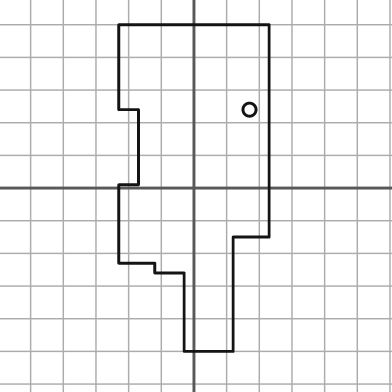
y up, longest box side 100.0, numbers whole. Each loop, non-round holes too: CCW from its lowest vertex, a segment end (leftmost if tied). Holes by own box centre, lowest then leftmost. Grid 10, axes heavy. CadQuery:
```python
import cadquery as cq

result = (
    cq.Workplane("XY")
    .moveTo(-3.0, -50.0)
    .lineTo(12.0, -50.0)
    .lineTo(12.0, -15.0)
    .lineTo(23.0, -15.0)
    .lineTo(23.0, 50.0)
    .lineTo(-23.0, 50.0)
    .lineTo(-23.0, 24.0)
    .lineTo(-17.0, 24.0)
    .lineTo(-17.0, 1.0)
    .lineTo(-23.0, 1.0)
    .lineTo(-23.0, -23.0)
    .lineTo(-12.0, -23.0)
    .lineTo(-12.0, -26.0)
    .lineTo(-3.0, -26.0)
    .close()
    .moveTo(17.0, 24.0)
    .circle(2.0)
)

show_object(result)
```